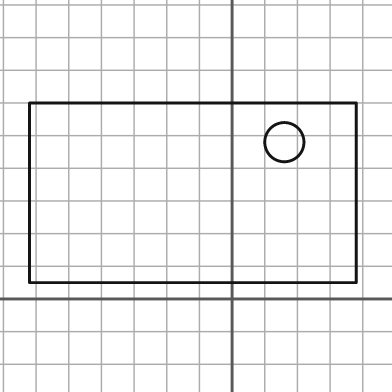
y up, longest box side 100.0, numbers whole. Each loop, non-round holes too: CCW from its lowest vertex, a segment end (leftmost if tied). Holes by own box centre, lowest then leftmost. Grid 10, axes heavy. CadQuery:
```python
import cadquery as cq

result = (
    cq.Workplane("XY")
    .moveTo(-62.0, 5.0)
    .lineTo(38.0, 5.0)
    .lineTo(38.0, 60.0)
    .lineTo(-62.0, 60.0)
    .close()
    .moveTo(16.0, 48.0)
    .circle(6.0)
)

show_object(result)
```